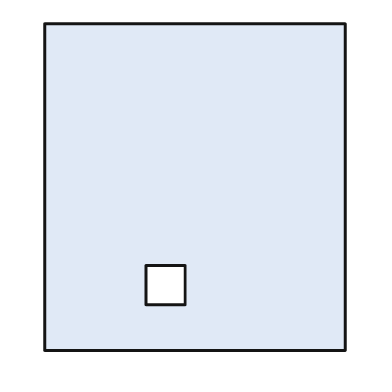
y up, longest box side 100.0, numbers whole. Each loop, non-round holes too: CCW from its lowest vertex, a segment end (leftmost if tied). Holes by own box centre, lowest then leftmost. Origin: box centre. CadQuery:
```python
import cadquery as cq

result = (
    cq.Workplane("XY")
    .moveTo(-46.0, -50.0)
    .lineTo(46.0, -50.0)
    .lineTo(46.0, 50.0)
    .lineTo(-46.0, 50.0)
    .close()
    .moveTo(-15.0, -36.0)
    .lineTo(-3.0, -36.0)
    .lineTo(-3.0, -24.0)
    .lineTo(-15.0, -24.0)
    .close()
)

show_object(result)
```